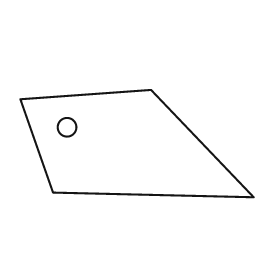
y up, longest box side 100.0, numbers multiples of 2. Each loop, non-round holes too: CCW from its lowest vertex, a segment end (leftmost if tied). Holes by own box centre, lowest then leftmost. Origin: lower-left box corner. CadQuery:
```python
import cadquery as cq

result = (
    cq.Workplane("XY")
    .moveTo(100.0, 0.0)
    .lineTo(56.0, 46.0)
    .lineTo(0.0, 42.0)
    .lineTo(14.0, 2.0)
    .close()
    .moveTo(20.0, 30.0)
    .circle(4.0)
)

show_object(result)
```